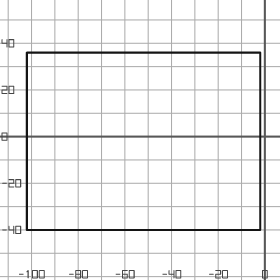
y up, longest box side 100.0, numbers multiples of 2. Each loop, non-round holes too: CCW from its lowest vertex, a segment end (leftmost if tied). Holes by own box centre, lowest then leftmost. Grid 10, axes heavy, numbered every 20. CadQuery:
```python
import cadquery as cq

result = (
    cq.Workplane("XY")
    .moveTo(-102.0, -40.0)
    .lineTo(-2.0, -40.0)
    .lineTo(-2.0, 36.0)
    .lineTo(-102.0, 36.0)
    .close()
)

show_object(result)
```